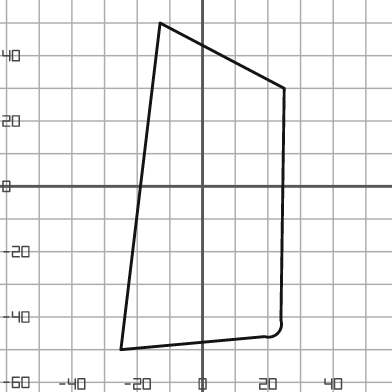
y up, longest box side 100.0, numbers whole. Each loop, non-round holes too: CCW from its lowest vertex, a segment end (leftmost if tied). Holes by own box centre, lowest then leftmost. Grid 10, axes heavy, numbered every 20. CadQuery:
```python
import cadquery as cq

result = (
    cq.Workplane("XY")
    .moveTo(-25.0, -50.0)
    .lineTo(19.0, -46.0)
    .threePointArc((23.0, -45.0), (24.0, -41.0))
    .lineTo(25.0, 30.0)
    .lineTo(-13.0, 50.0)
    .close()
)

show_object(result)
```